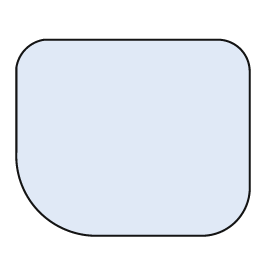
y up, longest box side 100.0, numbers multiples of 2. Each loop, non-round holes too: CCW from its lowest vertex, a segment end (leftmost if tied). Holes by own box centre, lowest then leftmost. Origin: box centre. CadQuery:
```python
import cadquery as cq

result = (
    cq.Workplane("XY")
    .moveTo(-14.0, -42.0)
    .lineTo(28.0, -42.0)
    .threePointArc((44.0, -36.0), (50.0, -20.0))
    .lineTo(50.0, 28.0)
    .threePointArc((46.0, 38.0), (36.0, 42.0))
    .lineTo(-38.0, 42.0)
    .threePointArc((-46.0, 38.0), (-50.0, 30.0))
    .lineTo(-50.0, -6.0)
    .threePointArc((-40.0, -32.0), (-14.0, -42.0))
    .close()
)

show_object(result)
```